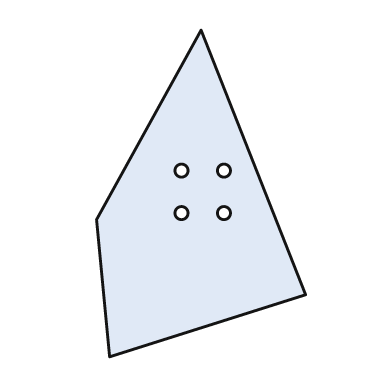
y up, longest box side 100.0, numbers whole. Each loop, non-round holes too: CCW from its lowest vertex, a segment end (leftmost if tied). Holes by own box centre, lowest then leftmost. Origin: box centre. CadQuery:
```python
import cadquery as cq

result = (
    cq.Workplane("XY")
    .moveTo(-28.0, -50.0)
    .lineTo(32.0, -31.0)
    .lineTo(0.0, 50.0)
    .lineTo(-32.0, -8.0)
    .close()
    .moveTo(-6.0, -6.0)
    .circle(2.0)
    .moveTo(7.0, -6.0)
    .circle(2.0)
    .moveTo(-6.0, 7.0)
    .circle(2.0)
    .moveTo(7.0, 7.0)
    .circle(2.0)
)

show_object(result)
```